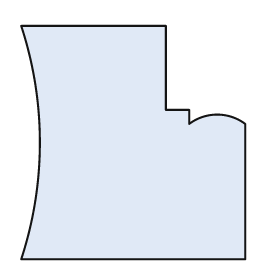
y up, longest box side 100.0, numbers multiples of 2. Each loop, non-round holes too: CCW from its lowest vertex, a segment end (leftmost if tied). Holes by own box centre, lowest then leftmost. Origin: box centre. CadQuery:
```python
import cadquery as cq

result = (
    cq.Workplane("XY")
    .moveTo(-48.0, -50.0)
    .lineTo(48.0, -50.0)
    .lineTo(48.0, 8.0)
    .threePointArc((36.0, 12.0), (24.0, 8.0))
    .lineTo(24.0, 14.0)
    .lineTo(14.0, 14.0)
    .lineTo(14.0, 50.0)
    .lineTo(-48.0, 50.0)
    .threePointArc((-40.0, 0.0), (-48.0, -50.0))
    .close()
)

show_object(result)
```